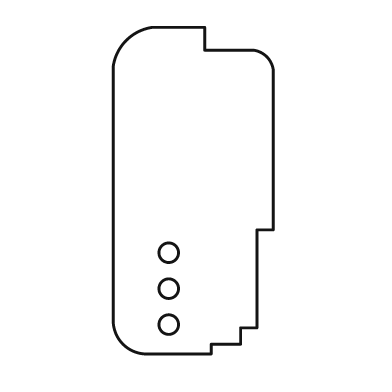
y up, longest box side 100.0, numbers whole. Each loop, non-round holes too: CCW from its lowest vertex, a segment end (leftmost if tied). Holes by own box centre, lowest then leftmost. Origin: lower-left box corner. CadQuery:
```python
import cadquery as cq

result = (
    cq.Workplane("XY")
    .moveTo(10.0, 0.0)
    .lineTo(30.0, 0.0)
    .lineTo(30.0, 3.0)
    .lineTo(39.0, 3.0)
    .lineTo(39.0, 8.0)
    .lineTo(44.0, 8.0)
    .lineTo(44.0, 38.0)
    .lineTo(49.0, 38.0)
    .lineTo(49.0, 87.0)
    .threePointArc((47.0, 91.0), (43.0, 93.0))
    .lineTo(28.0, 93.0)
    .lineTo(28.0, 100.0)
    .lineTo(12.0, 100.0)
    .threePointArc((4.0, 96.0), (0.0, 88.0))
    .lineTo(0.0, 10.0)
    .threePointArc((3.0, 3.0), (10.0, 0.0))
    .close()
    .moveTo(17.0, 9.0)
    .circle(3.0)
    .moveTo(17.0, 20.0)
    .circle(3.0)
    .moveTo(17.0, 31.0)
    .circle(3.0)
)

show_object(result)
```